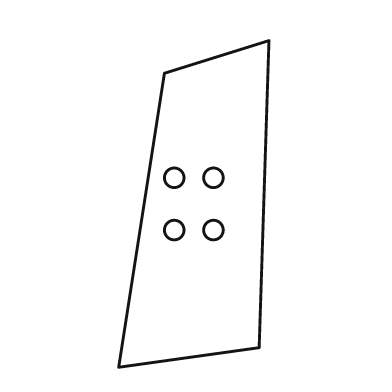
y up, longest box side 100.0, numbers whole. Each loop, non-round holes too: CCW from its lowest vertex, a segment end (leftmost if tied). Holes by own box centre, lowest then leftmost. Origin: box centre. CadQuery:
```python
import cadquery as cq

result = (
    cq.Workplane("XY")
    .moveTo(-23.0, -50.0)
    .lineTo(20.0, -44.0)
    .lineTo(23.0, 50.0)
    .lineTo(-9.0, 40.0)
    .close()
    .moveTo(-6.0, -8.0)
    .circle(3.0)
    .moveTo(6.0, -8.0)
    .circle(3.0)
    .moveTo(-6.0, 8.0)
    .circle(3.0)
    .moveTo(6.0, 8.0)
    .circle(3.0)
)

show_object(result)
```